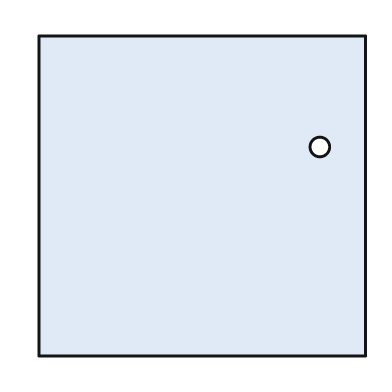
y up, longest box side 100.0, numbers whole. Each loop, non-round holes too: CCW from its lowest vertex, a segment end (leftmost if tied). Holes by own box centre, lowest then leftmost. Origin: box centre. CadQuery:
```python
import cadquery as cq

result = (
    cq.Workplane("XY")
    .moveTo(-50.0, -49.0)
    .lineTo(50.0, -49.0)
    .lineTo(50.0, 49.0)
    .lineTo(-50.0, 49.0)
    .close()
    .moveTo(36.0, 15.0)
    .circle(3.0)
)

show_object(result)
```